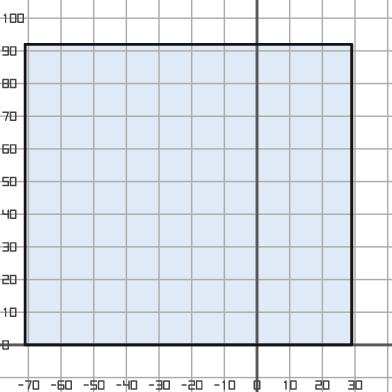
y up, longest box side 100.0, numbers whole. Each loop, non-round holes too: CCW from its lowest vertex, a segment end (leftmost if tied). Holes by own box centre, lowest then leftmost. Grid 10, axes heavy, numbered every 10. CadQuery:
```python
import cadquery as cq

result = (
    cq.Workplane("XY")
    .moveTo(-71.0, 0.0)
    .lineTo(29.0, 0.0)
    .lineTo(29.0, 92.0)
    .lineTo(-71.0, 92.0)
    .close()
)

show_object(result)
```